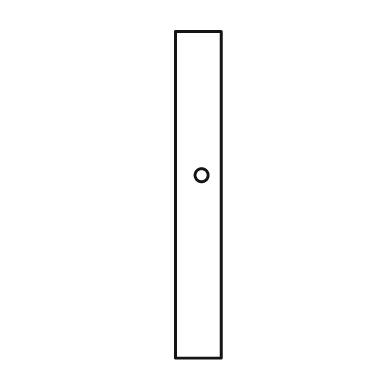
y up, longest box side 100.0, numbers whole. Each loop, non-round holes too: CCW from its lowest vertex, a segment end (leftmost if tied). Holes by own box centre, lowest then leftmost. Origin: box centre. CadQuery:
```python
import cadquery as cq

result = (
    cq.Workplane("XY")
    .moveTo(-7.0, -50.0)
    .lineTo(7.0, -50.0)
    .lineTo(7.0, 50.0)
    .lineTo(-7.0, 50.0)
    .close()
    .moveTo(1.0, 6.0)
    .circle(2.0)
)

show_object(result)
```